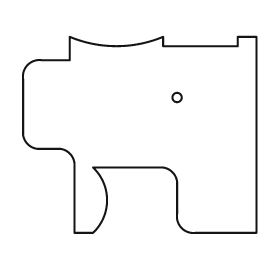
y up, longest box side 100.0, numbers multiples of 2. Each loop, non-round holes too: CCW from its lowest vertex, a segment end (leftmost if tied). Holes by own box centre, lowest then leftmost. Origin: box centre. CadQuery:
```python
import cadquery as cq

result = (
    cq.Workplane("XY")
    .moveTo(-28.0, -42.0)
    .lineTo(-20.0, -42.0)
    .threePointArc((-14.0, -28.0), (-20.0, -14.0))
    .lineTo(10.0, -14.0)
    .threePointArc((14.0, -16.0), (16.0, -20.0))
    .lineTo(16.0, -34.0)
    .threePointArc((18.0, -40.0), (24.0, -42.0))
    .lineTo(50.0, -42.0)
    .lineTo(50.0, 42.0)
    .lineTo(42.0, 42.0)
    .lineTo(42.0, 38.0)
    .lineTo(10.0, 38.0)
    .lineTo(10.0, 42.0)
    .threePointArc((-10.0, 38.0), (-30.0, 42.0))
    .lineTo(-30.0, 32.0)
    .lineTo(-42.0, 32.0)
    .threePointArc((-48.0, 30.0), (-50.0, 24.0))
    .lineTo(-50.0, 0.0)
    .threePointArc((-48.0, -4.0), (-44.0, -6.0))
    .lineTo(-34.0, -6.0)
    .threePointArc((-30.0, -8.0), (-28.0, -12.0))
    .close()
    .moveTo(16.0, 16.0)
    .circle(2.0)
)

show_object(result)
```